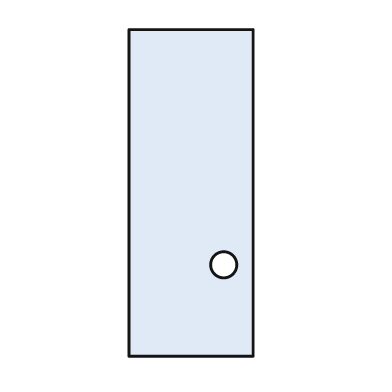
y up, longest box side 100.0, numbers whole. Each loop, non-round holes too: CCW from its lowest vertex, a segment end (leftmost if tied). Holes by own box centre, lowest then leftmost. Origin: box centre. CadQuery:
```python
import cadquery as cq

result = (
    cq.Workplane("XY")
    .moveTo(-19.0, -50.0)
    .lineTo(19.0, -50.0)
    .lineTo(19.0, 50.0)
    .lineTo(-19.0, 50.0)
    .close()
    .moveTo(10.0, -22.0)
    .circle(4.0)
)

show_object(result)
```